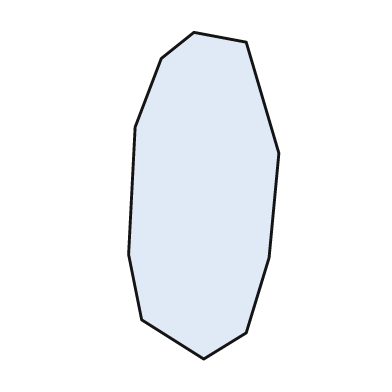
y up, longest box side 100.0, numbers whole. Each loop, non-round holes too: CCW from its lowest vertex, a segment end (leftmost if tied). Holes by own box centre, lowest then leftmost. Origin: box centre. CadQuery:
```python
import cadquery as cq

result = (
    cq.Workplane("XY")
    .moveTo(0.0, -50.0)
    .lineTo(13.0, -42.0)
    .lineTo(20.0, -19.0)
    .lineTo(23.0, 13.0)
    .lineTo(13.0, 47.0)
    .lineTo(-3.0, 50.0)
    .lineTo(-13.0, 42.0)
    .lineTo(-21.0, 21.0)
    .lineTo(-23.0, -18.0)
    .lineTo(-19.0, -38.0)
    .close()
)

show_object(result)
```